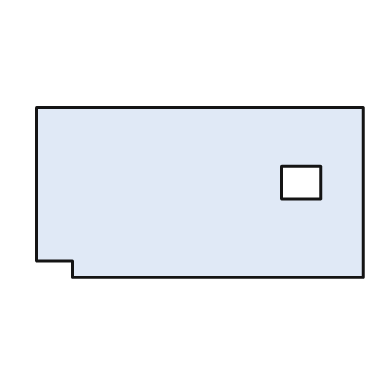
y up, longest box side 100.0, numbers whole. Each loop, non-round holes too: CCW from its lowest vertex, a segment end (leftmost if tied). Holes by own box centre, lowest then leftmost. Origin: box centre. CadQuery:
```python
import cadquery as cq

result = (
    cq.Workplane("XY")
    .moveTo(-39.0, -26.0)
    .lineTo(50.0, -26.0)
    .lineTo(50.0, 26.0)
    .lineTo(-50.0, 26.0)
    .lineTo(-50.0, -21.0)
    .lineTo(-39.0, -21.0)
    .close()
    .moveTo(25.0, -2.0)
    .lineTo(37.0, -2.0)
    .lineTo(37.0, 8.0)
    .lineTo(25.0, 8.0)
    .close()
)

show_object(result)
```